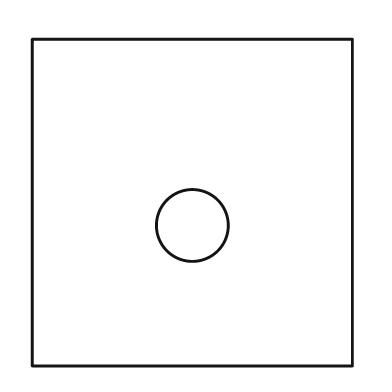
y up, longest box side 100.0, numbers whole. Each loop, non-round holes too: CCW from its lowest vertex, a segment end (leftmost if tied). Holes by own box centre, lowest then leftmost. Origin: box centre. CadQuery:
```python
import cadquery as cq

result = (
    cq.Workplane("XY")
    .moveTo(-49.0, -50.0)
    .lineTo(49.0, -50.0)
    .lineTo(49.0, 50.0)
    .lineTo(-49.0, 50.0)
    .close()
    .moveTo(0.0, -7.0)
    .circle(11.0)
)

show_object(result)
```